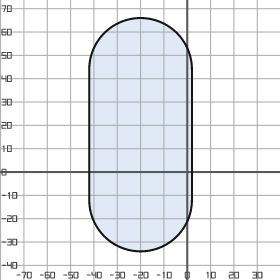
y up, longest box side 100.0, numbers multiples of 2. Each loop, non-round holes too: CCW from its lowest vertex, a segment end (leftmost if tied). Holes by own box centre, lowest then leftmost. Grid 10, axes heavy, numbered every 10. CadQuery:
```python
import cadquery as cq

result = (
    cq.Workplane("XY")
    .moveTo(-42.0, -12.0)
    .threePointArc((-20.0, -34.0), (2.0, -12.0))
    .lineTo(2.0, 44.0)
    .threePointArc((-20.0, 66.0), (-42.0, 44.0))
    .close()
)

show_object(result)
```